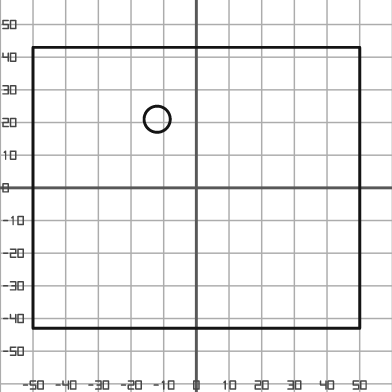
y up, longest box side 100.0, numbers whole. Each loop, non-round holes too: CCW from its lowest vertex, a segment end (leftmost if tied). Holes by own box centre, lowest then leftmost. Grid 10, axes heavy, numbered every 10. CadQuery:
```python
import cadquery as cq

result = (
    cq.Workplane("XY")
    .moveTo(-50.0, -43.0)
    .lineTo(50.0, -43.0)
    .lineTo(50.0, 43.0)
    .lineTo(-50.0, 43.0)
    .close()
    .moveTo(-12.0, 21.0)
    .circle(4.0)
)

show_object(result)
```